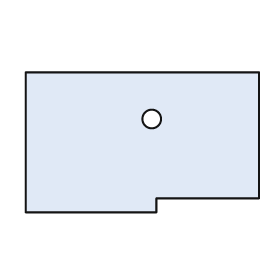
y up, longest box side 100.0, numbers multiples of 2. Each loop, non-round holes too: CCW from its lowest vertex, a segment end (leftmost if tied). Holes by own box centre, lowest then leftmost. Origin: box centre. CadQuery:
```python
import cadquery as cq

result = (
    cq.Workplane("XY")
    .moveTo(-50.0, -30.0)
    .lineTo(6.0, -30.0)
    .lineTo(6.0, -24.0)
    .lineTo(50.0, -24.0)
    .lineTo(50.0, 30.0)
    .lineTo(-50.0, 30.0)
    .close()
    .moveTo(4.0, 10.0)
    .circle(4.0)
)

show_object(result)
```